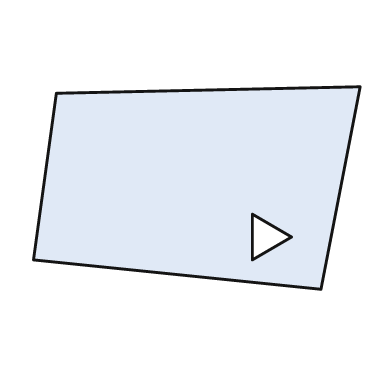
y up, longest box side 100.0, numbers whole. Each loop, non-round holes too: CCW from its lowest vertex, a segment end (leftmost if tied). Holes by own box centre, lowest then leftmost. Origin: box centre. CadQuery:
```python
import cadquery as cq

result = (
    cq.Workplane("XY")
    .moveTo(38.0, -31.0)
    .lineTo(50.0, 31.0)
    .lineTo(-43.0, 29.0)
    .lineTo(-50.0, -22.0)
    .close()
    .moveTo(17.0, -22.0)
    .lineTo(29.0, -15.0)
    .lineTo(17.0, -8.0)
    .close()
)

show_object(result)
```